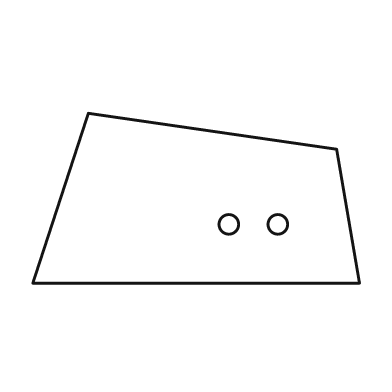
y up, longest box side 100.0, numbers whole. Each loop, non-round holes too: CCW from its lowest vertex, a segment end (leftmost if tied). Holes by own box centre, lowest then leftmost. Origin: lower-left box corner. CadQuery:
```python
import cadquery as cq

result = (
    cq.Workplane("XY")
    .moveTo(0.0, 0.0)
    .lineTo(100.0, 0.0)
    .lineTo(93.0, 41.0)
    .lineTo(17.0, 52.0)
    .close()
    .moveTo(60.0, 18.0)
    .circle(3.0)
    .moveTo(75.0, 18.0)
    .circle(3.0)
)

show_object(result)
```